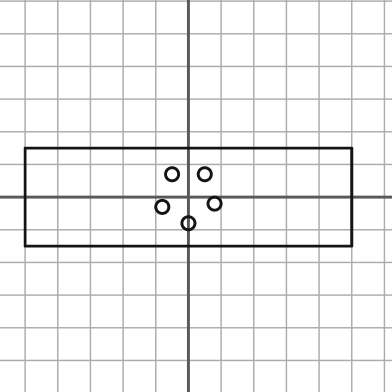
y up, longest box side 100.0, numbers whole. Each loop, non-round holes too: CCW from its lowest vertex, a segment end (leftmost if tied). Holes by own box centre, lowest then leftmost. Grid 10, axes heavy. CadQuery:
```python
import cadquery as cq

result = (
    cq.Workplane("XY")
    .moveTo(-50.0, -15.0)
    .lineTo(50.0, -15.0)
    .lineTo(50.0, 15.0)
    .lineTo(-50.0, 15.0)
    .close()
    .moveTo(0.0, -8.0)
    .circle(2.0)
    .moveTo(-8.0, -3.0)
    .circle(2.0)
    .moveTo(8.0, -2.0)
    .circle(2.0)
    .moveTo(-5.0, 7.0)
    .circle(2.0)
    .moveTo(5.0, 7.0)
    .circle(2.0)
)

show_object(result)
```